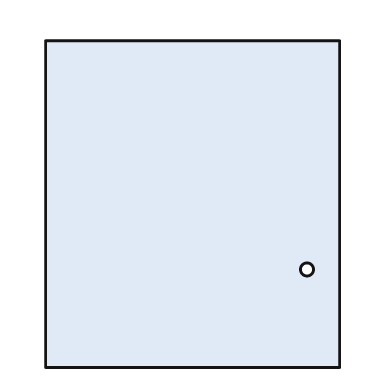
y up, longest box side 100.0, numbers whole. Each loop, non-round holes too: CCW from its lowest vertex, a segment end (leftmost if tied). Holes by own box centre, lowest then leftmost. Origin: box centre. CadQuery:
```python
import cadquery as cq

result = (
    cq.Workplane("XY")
    .moveTo(-45.0, -50.0)
    .lineTo(45.0, -50.0)
    .lineTo(45.0, 50.0)
    .lineTo(-45.0, 50.0)
    .close()
    .moveTo(35.0, -20.0)
    .circle(2.0)
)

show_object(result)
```